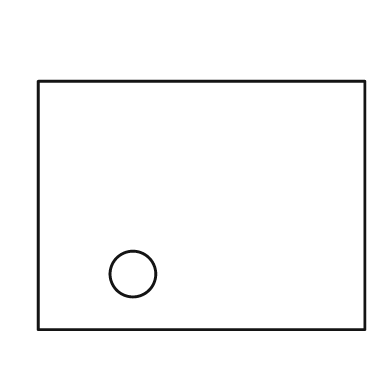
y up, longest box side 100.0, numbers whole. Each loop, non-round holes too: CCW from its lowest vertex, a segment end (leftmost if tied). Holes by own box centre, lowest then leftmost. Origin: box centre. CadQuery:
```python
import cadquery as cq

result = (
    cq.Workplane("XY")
    .moveTo(-50.0, -38.0)
    .lineTo(50.0, -38.0)
    .lineTo(50.0, 38.0)
    .lineTo(-50.0, 38.0)
    .close()
    .moveTo(-21.0, -21.0)
    .circle(7.0)
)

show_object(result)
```